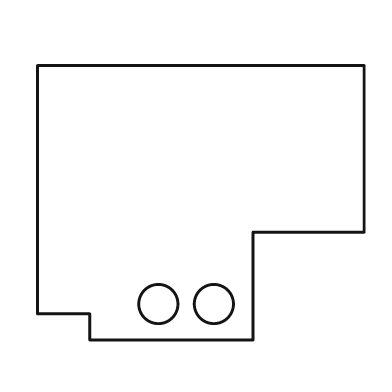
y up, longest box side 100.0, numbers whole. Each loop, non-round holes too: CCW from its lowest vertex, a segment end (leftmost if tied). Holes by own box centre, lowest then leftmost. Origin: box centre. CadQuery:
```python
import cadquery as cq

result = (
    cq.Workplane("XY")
    .moveTo(-34.0, -42.0)
    .lineTo(16.0, -42.0)
    .lineTo(16.0, -9.0)
    .lineTo(50.0, -9.0)
    .lineTo(50.0, 42.0)
    .lineTo(-50.0, 42.0)
    .lineTo(-50.0, -34.0)
    .lineTo(-34.0, -34.0)
    .close()
    .moveTo(-13.0, -31.0)
    .circle(6.0)
    .moveTo(4.0, -31.0)
    .circle(6.0)
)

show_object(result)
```